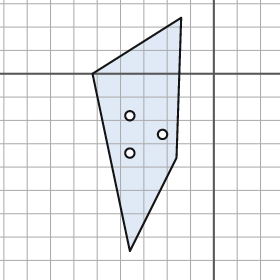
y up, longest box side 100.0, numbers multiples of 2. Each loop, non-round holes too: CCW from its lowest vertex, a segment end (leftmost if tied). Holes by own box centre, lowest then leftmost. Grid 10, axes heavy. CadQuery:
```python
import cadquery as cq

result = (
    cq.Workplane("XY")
    .moveTo(-36.0, -76.0)
    .lineTo(-16.0, -36.0)
    .lineTo(-14.0, 24.0)
    .lineTo(-52.0, 0.0)
    .close()
    .moveTo(-36.0, -34.0)
    .circle(2.0)
    .moveTo(-22.0, -26.0)
    .circle(2.0)
    .moveTo(-36.0, -18.0)
    .circle(2.0)
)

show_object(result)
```